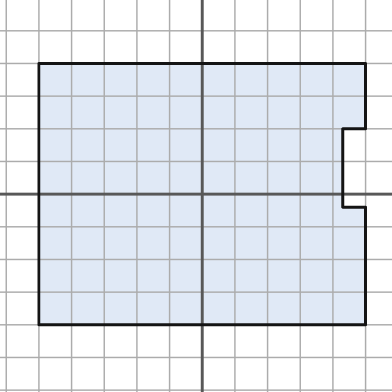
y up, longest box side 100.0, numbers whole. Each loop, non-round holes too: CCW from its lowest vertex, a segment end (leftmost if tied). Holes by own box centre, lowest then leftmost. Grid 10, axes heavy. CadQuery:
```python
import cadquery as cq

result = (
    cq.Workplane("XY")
    .moveTo(-50.0, -40.0)
    .lineTo(50.0, -40.0)
    .lineTo(50.0, -4.0)
    .lineTo(43.0, -4.0)
    .lineTo(43.0, 20.0)
    .lineTo(50.0, 20.0)
    .lineTo(50.0, 40.0)
    .lineTo(-50.0, 40.0)
    .close()
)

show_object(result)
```